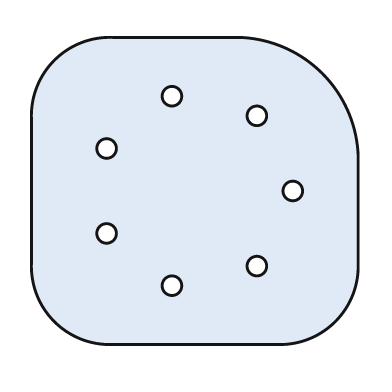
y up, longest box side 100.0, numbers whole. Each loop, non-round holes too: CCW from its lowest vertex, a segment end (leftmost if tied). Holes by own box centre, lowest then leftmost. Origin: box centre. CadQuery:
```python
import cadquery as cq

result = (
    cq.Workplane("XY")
    .moveTo(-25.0, -47.0)
    .lineTo(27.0, -47.0)
    .threePointArc((43.0, -40.0), (50.0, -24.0))
    .lineTo(50.0, 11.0)
    .threePointArc((39.0, 36.0), (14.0, 47.0))
    .lineTo(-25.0, 47.0)
    .threePointArc((-43.0, 40.0), (-50.0, 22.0))
    .lineTo(-50.0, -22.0)
    .threePointArc((-43.0, -40.0), (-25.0, -47.0))
    .close()
    .moveTo(-7.0, -29.0)
    .circle(3.0)
    .moveTo(19.0, -23.0)
    .circle(3.0)
    .moveTo(-27.0, -13.0)
    .circle(3.0)
    .moveTo(30.0, 0.0)
    .circle(3.0)
    .moveTo(-27.0, 13.0)
    .circle(3.0)
    .moveTo(19.0, 23.0)
    .circle(3.0)
    .moveTo(-7.0, 29.0)
    .circle(3.0)
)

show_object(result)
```